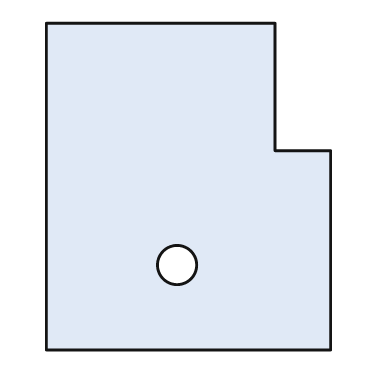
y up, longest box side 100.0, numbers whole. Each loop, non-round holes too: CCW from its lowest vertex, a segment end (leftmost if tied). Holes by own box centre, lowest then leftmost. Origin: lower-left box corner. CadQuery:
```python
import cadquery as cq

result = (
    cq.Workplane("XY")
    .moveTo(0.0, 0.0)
    .lineTo(87.0, 0.0)
    .lineTo(87.0, 61.0)
    .lineTo(70.0, 61.0)
    .lineTo(70.0, 100.0)
    .lineTo(0.0, 100.0)
    .close()
    .moveTo(40.0, 26.0)
    .circle(6.0)
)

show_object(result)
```